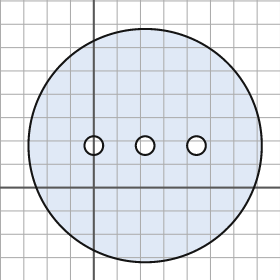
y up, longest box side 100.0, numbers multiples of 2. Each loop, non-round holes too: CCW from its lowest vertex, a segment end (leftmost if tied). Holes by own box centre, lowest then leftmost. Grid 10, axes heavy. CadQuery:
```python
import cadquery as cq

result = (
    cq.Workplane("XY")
    .moveTo(22.0, 18.0)
    .circle(50.0)
    .moveTo(0.0, 18.0)
    .circle(4.0)
    .moveTo(22.0, 18.0)
    .circle(4.0)
    .moveTo(44.0, 18.0)
    .circle(4.0)
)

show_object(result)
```